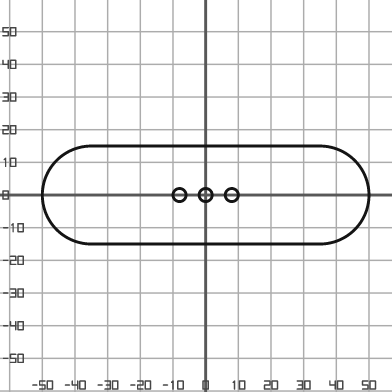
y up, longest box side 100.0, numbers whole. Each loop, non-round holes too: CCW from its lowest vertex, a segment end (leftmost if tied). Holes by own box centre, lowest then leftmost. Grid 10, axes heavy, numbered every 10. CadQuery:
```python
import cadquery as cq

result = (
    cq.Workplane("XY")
    .moveTo(-35.0, -15.0)
    .lineTo(35.0, -15.0)
    .threePointArc((50.0, 0.0), (35.0, 15.0))
    .lineTo(-35.0, 15.0)
    .threePointArc((-50.0, 0.0), (-35.0, -15.0))
    .close()
    .moveTo(-8.0, 0.0)
    .circle(2.0)
    .moveTo(0.0, 0.0)
    .circle(2.0)
    .moveTo(8.0, 0.0)
    .circle(2.0)
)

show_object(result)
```